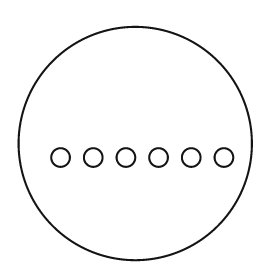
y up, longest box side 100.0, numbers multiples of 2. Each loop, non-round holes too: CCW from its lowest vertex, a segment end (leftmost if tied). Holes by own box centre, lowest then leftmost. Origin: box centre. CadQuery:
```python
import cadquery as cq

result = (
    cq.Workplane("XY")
    .moveTo(0.0, 0.0)
    .circle(50.0)
    .moveTo(-32.0, -6.0)
    .circle(4.0)
    .moveTo(-18.0, -6.0)
    .circle(4.0)
    .moveTo(-4.0, -6.0)
    .circle(4.0)
    .moveTo(10.0, -6.0)
    .circle(4.0)
    .moveTo(24.0, -6.0)
    .circle(4.0)
    .moveTo(38.0, -6.0)
    .circle(4.0)
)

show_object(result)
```